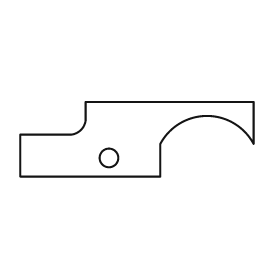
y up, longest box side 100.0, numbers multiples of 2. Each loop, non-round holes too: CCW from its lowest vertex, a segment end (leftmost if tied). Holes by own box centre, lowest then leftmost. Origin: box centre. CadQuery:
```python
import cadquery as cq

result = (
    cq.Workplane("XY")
    .moveTo(-50.0, -16.0)
    .lineTo(10.0, -16.0)
    .lineTo(10.0, -2.0)
    .threePointArc((30.0, 10.0), (50.0, -2.0))
    .lineTo(50.0, 16.0)
    .lineTo(-22.0, 16.0)
    .lineTo(-22.0, 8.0)
    .threePointArc((-24.0, 4.0), (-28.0, 2.0))
    .lineTo(-50.0, 2.0)
    .close()
    .moveTo(-12.0, -8.0)
    .circle(4.0)
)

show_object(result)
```